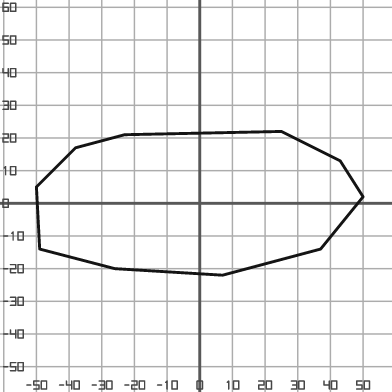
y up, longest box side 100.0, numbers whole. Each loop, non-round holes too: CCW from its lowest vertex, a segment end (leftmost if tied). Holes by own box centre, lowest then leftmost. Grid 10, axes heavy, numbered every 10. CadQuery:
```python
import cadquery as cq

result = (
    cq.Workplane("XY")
    .moveTo(7.0, -22.0)
    .lineTo(37.0, -14.0)
    .lineTo(50.0, 2.0)
    .lineTo(43.0, 13.0)
    .lineTo(25.0, 22.0)
    .lineTo(-23.0, 21.0)
    .lineTo(-38.0, 17.0)
    .lineTo(-50.0, 5.0)
    .lineTo(-49.0, -14.0)
    .lineTo(-26.0, -20.0)
    .close()
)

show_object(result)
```